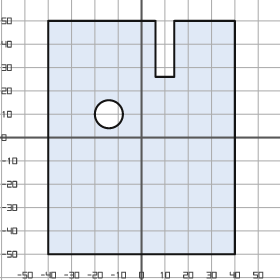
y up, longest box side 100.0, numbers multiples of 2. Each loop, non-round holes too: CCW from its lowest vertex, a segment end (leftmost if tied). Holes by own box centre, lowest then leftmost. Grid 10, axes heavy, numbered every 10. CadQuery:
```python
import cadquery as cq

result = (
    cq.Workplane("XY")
    .moveTo(-40.0, -50.0)
    .lineTo(40.0, -50.0)
    .lineTo(40.0, 50.0)
    .lineTo(14.0, 50.0)
    .lineTo(14.0, 26.0)
    .lineTo(6.0, 26.0)
    .lineTo(6.0, 50.0)
    .lineTo(-40.0, 50.0)
    .close()
    .moveTo(-14.0, 10.0)
    .circle(6.0)
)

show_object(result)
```